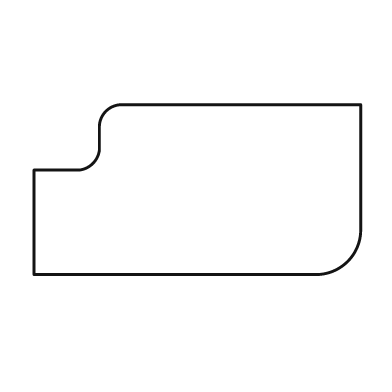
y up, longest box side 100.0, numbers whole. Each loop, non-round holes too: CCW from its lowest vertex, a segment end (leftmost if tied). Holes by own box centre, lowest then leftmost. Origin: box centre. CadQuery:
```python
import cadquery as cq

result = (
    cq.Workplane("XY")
    .moveTo(-50.0, -26.0)
    .lineTo(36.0, -26.0)
    .threePointArc((46.0, -22.0), (50.0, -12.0))
    .lineTo(50.0, 26.0)
    .lineTo(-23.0, 26.0)
    .threePointArc((-28.0, 24.0), (-30.0, 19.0))
    .lineTo(-30.0, 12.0)
    .threePointArc((-32.0, 8.0), (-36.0, 6.0))
    .lineTo(-50.0, 6.0)
    .close()
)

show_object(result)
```